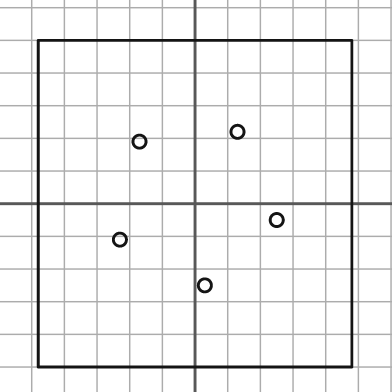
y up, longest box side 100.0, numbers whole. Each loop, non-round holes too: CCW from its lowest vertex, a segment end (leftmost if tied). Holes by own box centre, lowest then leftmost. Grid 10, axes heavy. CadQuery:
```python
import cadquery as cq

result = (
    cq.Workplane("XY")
    .moveTo(-48.0, -50.0)
    .lineTo(48.0, -50.0)
    .lineTo(48.0, 50.0)
    .lineTo(-48.0, 50.0)
    .close()
    .moveTo(3.0, -25.0)
    .circle(2.0)
    .moveTo(-23.0, -11.0)
    .circle(2.0)
    .moveTo(25.0, -5.0)
    .circle(2.0)
    .moveTo(-17.0, 19.0)
    .circle(2.0)
    .moveTo(13.0, 22.0)
    .circle(2.0)
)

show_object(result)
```